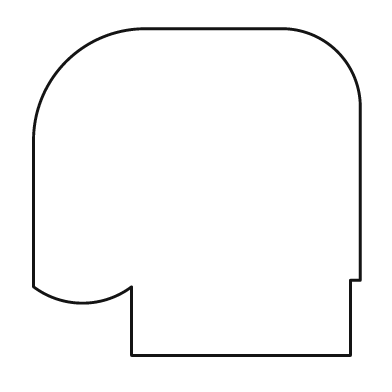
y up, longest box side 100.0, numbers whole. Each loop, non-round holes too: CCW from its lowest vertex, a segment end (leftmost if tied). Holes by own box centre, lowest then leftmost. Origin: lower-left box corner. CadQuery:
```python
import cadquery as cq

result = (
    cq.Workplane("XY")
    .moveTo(30.0, 0.0)
    .lineTo(97.0, 0.0)
    .lineTo(97.0, 23.0)
    .lineTo(100.0, 23.0)
    .lineTo(100.0, 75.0)
    .threePointArc((93.0, 93.0), (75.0, 100.0))
    .lineTo(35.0, 100.0)
    .threePointArc((10.0, 90.0), (0.0, 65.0))
    .lineTo(0.0, 21.0)
    .threePointArc((15.0, 16.0), (30.0, 21.0))
    .close()
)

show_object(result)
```